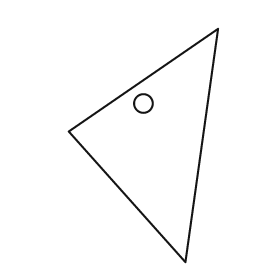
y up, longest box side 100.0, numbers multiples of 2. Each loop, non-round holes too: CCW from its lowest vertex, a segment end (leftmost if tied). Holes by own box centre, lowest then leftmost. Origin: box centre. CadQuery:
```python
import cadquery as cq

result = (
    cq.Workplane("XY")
    .moveTo(18.0, -50.0)
    .lineTo(32.0, 50.0)
    .lineTo(-32.0, 6.0)
    .close()
    .moveTo(0.0, 18.0)
    .circle(4.0)
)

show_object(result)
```